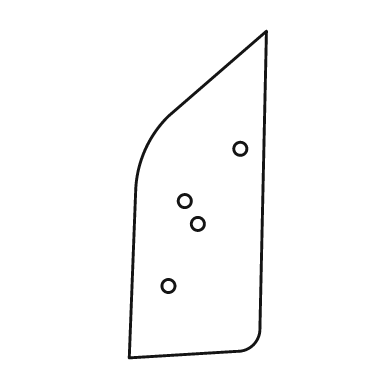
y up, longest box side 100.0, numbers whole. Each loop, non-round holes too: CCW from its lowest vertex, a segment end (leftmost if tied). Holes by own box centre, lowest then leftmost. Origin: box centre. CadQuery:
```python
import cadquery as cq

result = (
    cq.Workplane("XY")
    .moveTo(-21.0, -50.0)
    .lineTo(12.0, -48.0)
    .threePointArc((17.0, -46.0), (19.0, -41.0))
    .lineTo(21.0, 50.0)
    .lineTo(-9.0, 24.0)
    .threePointArc((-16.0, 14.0), (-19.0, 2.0))
    .close()
    .moveTo(-9.0, -28.0)
    .circle(2.0)
    .moveTo(0.0, -9.0)
    .circle(2.0)
    .moveTo(-4.0, -2.0)
    .circle(2.0)
    .moveTo(13.0, 14.0)
    .circle(2.0)
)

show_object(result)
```